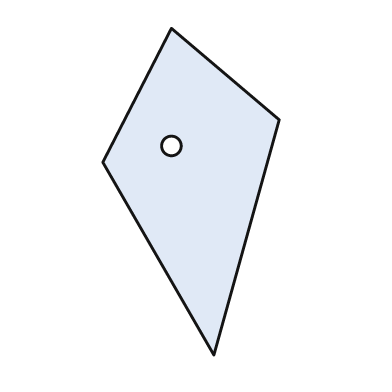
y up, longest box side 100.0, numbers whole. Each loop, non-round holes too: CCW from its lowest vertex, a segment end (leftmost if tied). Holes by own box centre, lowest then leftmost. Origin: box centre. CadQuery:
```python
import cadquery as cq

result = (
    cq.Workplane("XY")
    .moveTo(7.0, -50.0)
    .lineTo(27.0, 22.0)
    .lineTo(-6.0, 50.0)
    .lineTo(-27.0, 9.0)
    .close()
    .moveTo(-6.0, 14.0)
    .circle(3.0)
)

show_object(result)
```